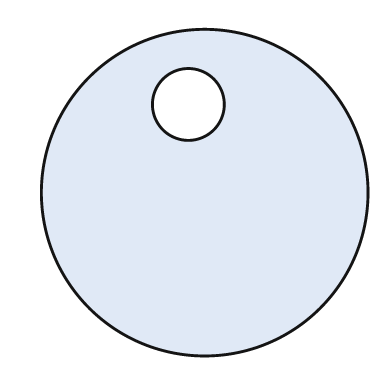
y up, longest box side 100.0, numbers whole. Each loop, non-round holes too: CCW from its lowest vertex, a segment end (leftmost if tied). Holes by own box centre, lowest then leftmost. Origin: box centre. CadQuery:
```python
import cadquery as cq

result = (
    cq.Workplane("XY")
    .moveTo(0.0, 0.0)
    .circle(50.0)
    .moveTo(-5.0, 27.0)
    .circle(11.0)
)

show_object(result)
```